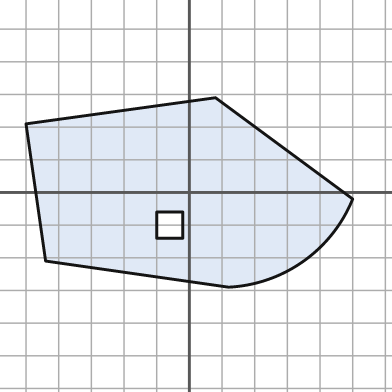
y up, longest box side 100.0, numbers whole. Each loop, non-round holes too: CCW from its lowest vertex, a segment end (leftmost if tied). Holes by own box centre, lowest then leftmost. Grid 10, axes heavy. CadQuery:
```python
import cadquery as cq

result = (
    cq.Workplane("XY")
    .moveTo(12.0, -29.0)
    .threePointArc((35.0, -21.0), (50.0, -2.0))
    .lineTo(8.0, 29.0)
    .lineTo(-50.0, 21.0)
    .lineTo(-44.0, -21.0)
    .close()
    .moveTo(-10.0, -14.0)
    .lineTo(-2.0, -14.0)
    .lineTo(-2.0, -6.0)
    .lineTo(-10.0, -6.0)
    .close()
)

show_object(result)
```